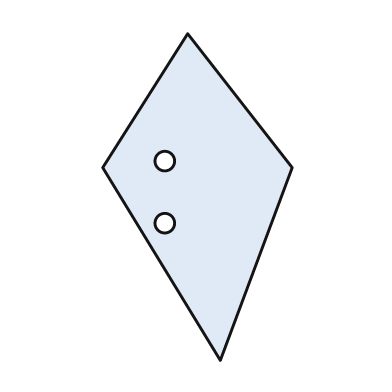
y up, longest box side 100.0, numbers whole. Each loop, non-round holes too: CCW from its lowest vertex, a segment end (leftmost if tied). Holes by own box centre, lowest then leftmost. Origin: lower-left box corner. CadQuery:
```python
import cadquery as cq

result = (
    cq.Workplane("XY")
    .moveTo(36.0, 0.0)
    .lineTo(58.0, 59.0)
    .lineTo(26.0, 100.0)
    .lineTo(0.0, 59.0)
    .close()
    .moveTo(19.0, 42.0)
    .circle(3.0)
    .moveTo(19.0, 61.0)
    .circle(3.0)
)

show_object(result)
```